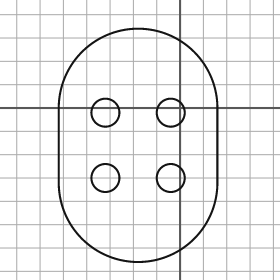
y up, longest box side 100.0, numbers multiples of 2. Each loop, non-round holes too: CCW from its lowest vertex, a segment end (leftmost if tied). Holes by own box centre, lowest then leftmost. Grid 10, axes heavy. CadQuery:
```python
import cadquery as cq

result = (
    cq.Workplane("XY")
    .moveTo(-52.0, -32.0)
    .threePointArc((-18.0, -66.0), (16.0, -32.0))
    .lineTo(16.0, 0.0)
    .threePointArc((-18.0, 34.0), (-52.0, 0.0))
    .close()
    .moveTo(-32.0, -30.0)
    .circle(6.0)
    .moveTo(-4.0, -30.0)
    .circle(6.0)
    .moveTo(-32.0, -2.0)
    .circle(6.0)
    .moveTo(-4.0, -2.0)
    .circle(6.0)
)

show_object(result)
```